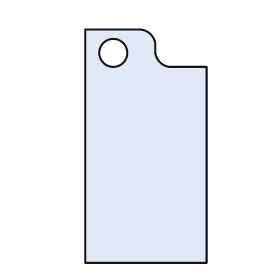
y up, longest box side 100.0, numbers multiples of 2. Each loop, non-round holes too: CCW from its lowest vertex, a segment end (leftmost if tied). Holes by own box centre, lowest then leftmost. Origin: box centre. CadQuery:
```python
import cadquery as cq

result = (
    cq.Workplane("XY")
    .moveTo(-26.0, -50.0)
    .lineTo(26.0, -50.0)
    .lineTo(26.0, 34.0)
    .lineTo(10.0, 34.0)
    .threePointArc((6.0, 36.0), (4.0, 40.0))
    .lineTo(4.0, 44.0)
    .threePointArc((2.0, 48.0), (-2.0, 50.0))
    .lineTo(-26.0, 50.0)
    .close()
    .moveTo(-14.0, 40.0)
    .circle(6.0)
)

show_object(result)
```